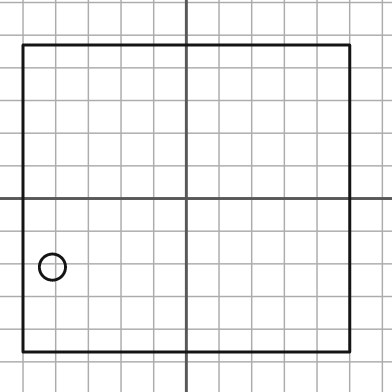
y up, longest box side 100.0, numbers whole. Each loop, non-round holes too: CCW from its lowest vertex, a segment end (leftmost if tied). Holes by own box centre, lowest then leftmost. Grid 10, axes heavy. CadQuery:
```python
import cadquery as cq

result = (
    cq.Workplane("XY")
    .moveTo(-50.0, -47.0)
    .lineTo(50.0, -47.0)
    .lineTo(50.0, 47.0)
    .lineTo(-50.0, 47.0)
    .close()
    .moveTo(-41.0, -21.0)
    .circle(4.0)
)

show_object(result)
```